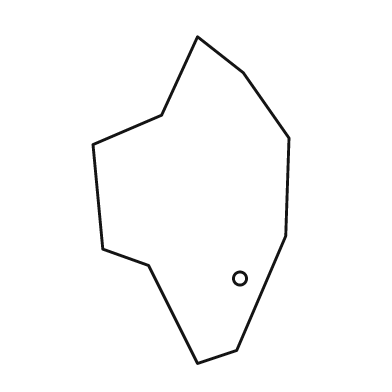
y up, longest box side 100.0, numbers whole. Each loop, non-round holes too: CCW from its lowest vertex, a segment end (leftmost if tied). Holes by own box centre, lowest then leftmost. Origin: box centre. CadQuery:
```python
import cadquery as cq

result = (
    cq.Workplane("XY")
    .moveTo(2.0, -50.0)
    .lineTo(14.0, -46.0)
    .lineTo(29.0, -11.0)
    .lineTo(30.0, 19.0)
    .lineTo(16.0, 39.0)
    .lineTo(2.0, 50.0)
    .lineTo(-9.0, 26.0)
    .lineTo(-30.0, 17.0)
    .lineTo(-27.0, -15.0)
    .lineTo(-13.0, -20.0)
    .close()
    .moveTo(15.0, -24.0)
    .circle(2.0)
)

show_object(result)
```